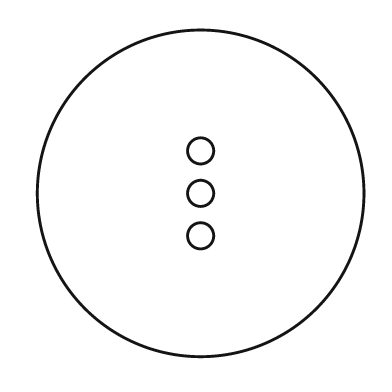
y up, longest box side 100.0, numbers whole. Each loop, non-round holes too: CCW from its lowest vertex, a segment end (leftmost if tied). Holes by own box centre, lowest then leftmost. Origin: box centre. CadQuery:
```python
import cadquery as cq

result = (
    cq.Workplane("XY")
    .moveTo(0.0, 0.0)
    .circle(50.0)
    .moveTo(0.0, -13.0)
    .circle(4.0)
    .moveTo(0.0, 0.0)
    .circle(4.0)
    .moveTo(0.0, 13.0)
    .circle(4.0)
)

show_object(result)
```